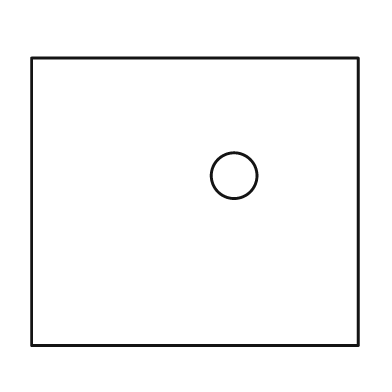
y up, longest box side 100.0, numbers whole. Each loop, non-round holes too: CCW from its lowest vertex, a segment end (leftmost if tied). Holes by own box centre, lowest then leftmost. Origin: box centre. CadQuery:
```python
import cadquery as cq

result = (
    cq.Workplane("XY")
    .moveTo(-50.0, -44.0)
    .lineTo(50.0, -44.0)
    .lineTo(50.0, 44.0)
    .lineTo(-50.0, 44.0)
    .close()
    .moveTo(12.0, 8.0)
    .circle(7.0)
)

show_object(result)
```